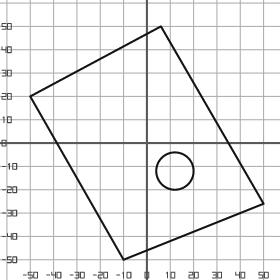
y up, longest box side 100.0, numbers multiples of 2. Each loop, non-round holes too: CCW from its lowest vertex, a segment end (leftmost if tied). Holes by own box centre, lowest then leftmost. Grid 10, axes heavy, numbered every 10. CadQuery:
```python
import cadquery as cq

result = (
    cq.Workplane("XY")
    .moveTo(-10.0, -50.0)
    .lineTo(50.0, -26.0)
    .lineTo(6.0, 50.0)
    .lineTo(-50.0, 20.0)
    .close()
    .moveTo(12.0, -12.0)
    .circle(8.0)
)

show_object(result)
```